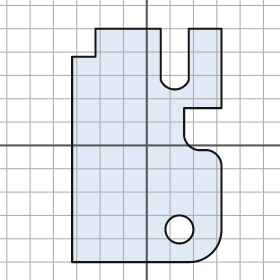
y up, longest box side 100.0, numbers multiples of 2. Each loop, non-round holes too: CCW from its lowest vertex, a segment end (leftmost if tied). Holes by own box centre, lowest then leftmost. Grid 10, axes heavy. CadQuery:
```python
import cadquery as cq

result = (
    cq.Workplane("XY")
    .moveTo(-32.0, -50.0)
    .lineTo(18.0, -50.0)
    .threePointArc((28.0, -46.0), (32.0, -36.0))
    .lineTo(32.0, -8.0)
    .threePointArc((30.0, -4.0), (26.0, -2.0))
    .lineTo(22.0, -2.0)
    .threePointArc((18.0, 0.0), (16.0, 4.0))
    .lineTo(16.0, 16.0)
    .lineTo(32.0, 16.0)
    .lineTo(32.0, 50.0)
    .lineTo(18.0, 50.0)
    .lineTo(18.0, 28.0)
    .threePointArc((12.0, 24.0), (6.0, 28.0))
    .lineTo(6.0, 50.0)
    .lineTo(-22.0, 50.0)
    .lineTo(-22.0, 38.0)
    .lineTo(-32.0, 38.0)
    .close()
    .moveTo(14.0, -36.0)
    .circle(6.0)
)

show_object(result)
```